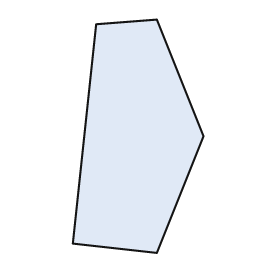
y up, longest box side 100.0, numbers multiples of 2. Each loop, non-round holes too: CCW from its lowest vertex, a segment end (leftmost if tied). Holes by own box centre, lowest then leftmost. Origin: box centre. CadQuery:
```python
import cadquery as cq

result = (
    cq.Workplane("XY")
    .moveTo(8.0, -50.0)
    .lineTo(28.0, 0.0)
    .lineTo(8.0, 50.0)
    .lineTo(-18.0, 48.0)
    .lineTo(-28.0, -46.0)
    .close()
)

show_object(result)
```